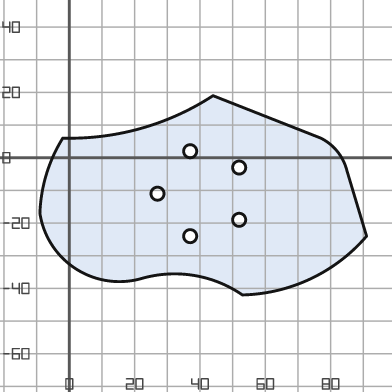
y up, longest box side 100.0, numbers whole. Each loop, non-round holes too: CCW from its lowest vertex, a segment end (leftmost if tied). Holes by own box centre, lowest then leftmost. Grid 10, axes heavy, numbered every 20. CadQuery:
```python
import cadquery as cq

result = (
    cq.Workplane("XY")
    .moveTo(53.0, -42.0)
    .threePointArc((74.0, -37.0), (91.0, -24.0))
    .lineTo(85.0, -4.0)
    .threePointArc((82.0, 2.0), (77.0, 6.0))
    .lineTo(44.0, 19.0)
    .threePointArc((22.0, 9.0), (-2.0, 6.0))
    .threePointArc((-7.0, -5.0), (-9.0, -17.0))
    .threePointArc((2.0, -34.0), (22.0, -37.0))
    .threePointArc((38.0, -36.0), (53.0, -42.0))
    .close()
    .moveTo(37.0, -24.0)
    .circle(2.0)
    .moveTo(52.0, -19.0)
    .circle(2.0)
    .moveTo(27.0, -11.0)
    .circle(2.0)
    .moveTo(52.0, -3.0)
    .circle(2.0)
    .moveTo(37.0, 2.0)
    .circle(2.0)
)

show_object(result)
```